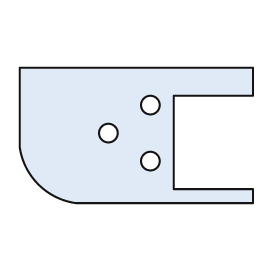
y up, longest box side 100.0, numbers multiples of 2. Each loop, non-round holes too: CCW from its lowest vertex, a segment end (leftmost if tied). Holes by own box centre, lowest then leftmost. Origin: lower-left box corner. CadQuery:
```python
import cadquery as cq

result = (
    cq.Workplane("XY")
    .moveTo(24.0, 0.0)
    .lineTo(100.0, 0.0)
    .lineTo(100.0, 6.0)
    .lineTo(66.0, 6.0)
    .lineTo(66.0, 46.0)
    .lineTo(100.0, 46.0)
    .lineTo(100.0, 58.0)
    .lineTo(0.0, 58.0)
    .lineTo(0.0, 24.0)
    .threePointArc((8.0, 8.0), (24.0, 0.0))
    .close()
    .moveTo(56.0, 18.0)
    .circle(4.0)
    .moveTo(38.0, 30.0)
    .circle(4.0)
    .moveTo(56.0, 42.0)
    .circle(4.0)
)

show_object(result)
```